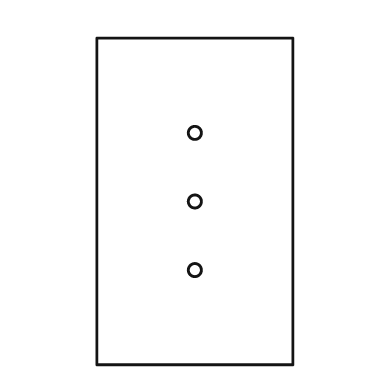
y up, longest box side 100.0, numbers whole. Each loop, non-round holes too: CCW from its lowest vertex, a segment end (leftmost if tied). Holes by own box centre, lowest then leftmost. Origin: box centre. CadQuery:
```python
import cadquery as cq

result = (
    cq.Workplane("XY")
    .moveTo(-30.0, -50.0)
    .lineTo(30.0, -50.0)
    .lineTo(30.0, 50.0)
    .lineTo(-30.0, 50.0)
    .close()
    .moveTo(0.0, -21.0)
    .circle(2.0)
    .moveTo(0.0, 0.0)
    .circle(2.0)
    .moveTo(0.0, 21.0)
    .circle(2.0)
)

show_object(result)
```